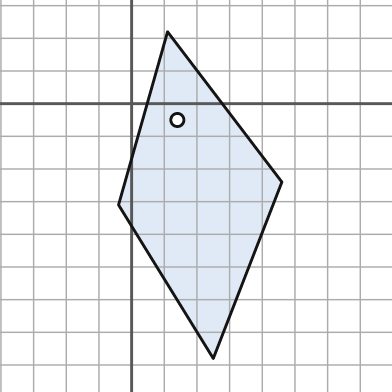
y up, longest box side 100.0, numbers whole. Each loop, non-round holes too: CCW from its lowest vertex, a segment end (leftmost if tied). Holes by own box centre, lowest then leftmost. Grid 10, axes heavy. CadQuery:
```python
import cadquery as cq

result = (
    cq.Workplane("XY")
    .moveTo(25.0, -78.0)
    .lineTo(46.0, -24.0)
    .lineTo(11.0, 22.0)
    .lineTo(-4.0, -31.0)
    .close()
    .moveTo(14.0, -5.0)
    .circle(2.0)
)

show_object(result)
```